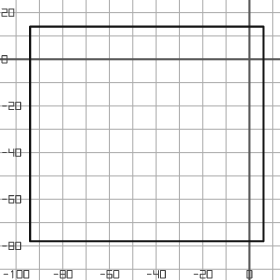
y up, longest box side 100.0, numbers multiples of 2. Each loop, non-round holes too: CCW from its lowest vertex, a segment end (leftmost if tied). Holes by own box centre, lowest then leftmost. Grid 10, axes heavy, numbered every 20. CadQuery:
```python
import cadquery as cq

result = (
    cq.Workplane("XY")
    .moveTo(-94.0, -78.0)
    .lineTo(6.0, -78.0)
    .lineTo(6.0, 14.0)
    .lineTo(-94.0, 14.0)
    .close()
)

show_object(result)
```